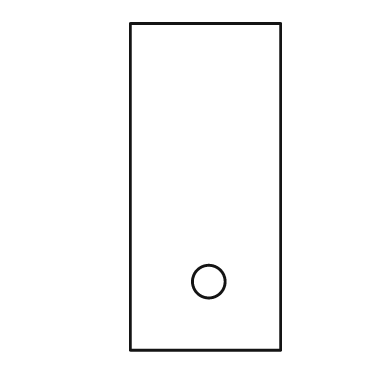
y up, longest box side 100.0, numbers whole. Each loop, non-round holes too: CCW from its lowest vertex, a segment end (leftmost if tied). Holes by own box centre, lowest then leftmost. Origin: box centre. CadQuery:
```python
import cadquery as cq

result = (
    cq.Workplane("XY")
    .moveTo(-23.0, -50.0)
    .lineTo(23.0, -50.0)
    .lineTo(23.0, 50.0)
    .lineTo(-23.0, 50.0)
    .close()
    .moveTo(1.0, -29.0)
    .circle(5.0)
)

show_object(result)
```